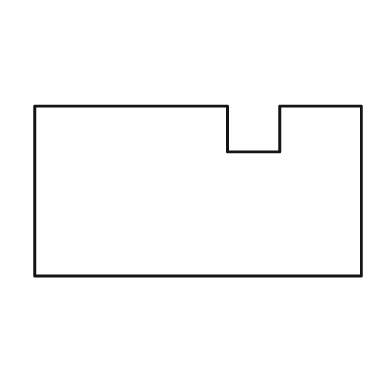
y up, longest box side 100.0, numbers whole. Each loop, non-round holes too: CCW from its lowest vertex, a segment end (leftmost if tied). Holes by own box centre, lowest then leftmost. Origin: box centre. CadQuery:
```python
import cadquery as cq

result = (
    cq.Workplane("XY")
    .moveTo(-50.0, -26.0)
    .lineTo(50.0, -26.0)
    .lineTo(50.0, 26.0)
    .lineTo(25.0, 26.0)
    .lineTo(25.0, 12.0)
    .lineTo(9.0, 12.0)
    .lineTo(9.0, 26.0)
    .lineTo(-50.0, 26.0)
    .close()
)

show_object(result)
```